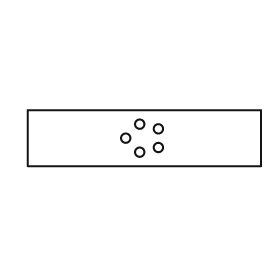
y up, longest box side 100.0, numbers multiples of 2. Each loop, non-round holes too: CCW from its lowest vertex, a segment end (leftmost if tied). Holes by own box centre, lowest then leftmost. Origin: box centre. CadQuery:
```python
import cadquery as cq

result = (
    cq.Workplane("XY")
    .moveTo(-50.0, -12.0)
    .lineTo(50.0, -12.0)
    .lineTo(50.0, 12.0)
    .lineTo(-50.0, 12.0)
    .close()
    .moveTo(-2.0, -6.0)
    .circle(2.0)
    .moveTo(6.0, -4.0)
    .circle(2.0)
    .moveTo(-8.0, 0.0)
    .circle(2.0)
    .moveTo(6.0, 4.0)
    .circle(2.0)
    .moveTo(-2.0, 6.0)
    .circle(2.0)
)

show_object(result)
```